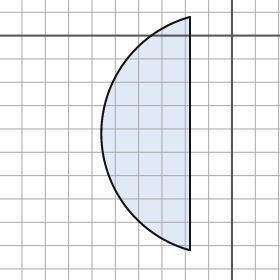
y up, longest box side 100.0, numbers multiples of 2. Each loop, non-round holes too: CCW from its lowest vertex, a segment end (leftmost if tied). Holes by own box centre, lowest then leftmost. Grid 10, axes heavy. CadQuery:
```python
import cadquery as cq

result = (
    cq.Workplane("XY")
    .moveTo(-18.0, -92.0)
    .lineTo(-18.0, 8.0)
    .threePointArc((-56.0, -42.0), (-18.0, -92.0))
    .close()
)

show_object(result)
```